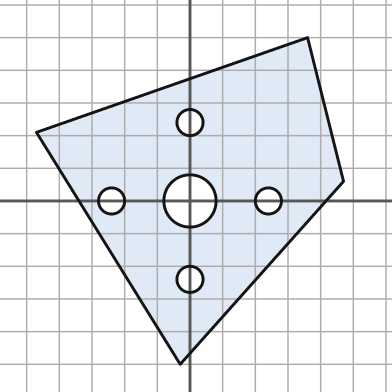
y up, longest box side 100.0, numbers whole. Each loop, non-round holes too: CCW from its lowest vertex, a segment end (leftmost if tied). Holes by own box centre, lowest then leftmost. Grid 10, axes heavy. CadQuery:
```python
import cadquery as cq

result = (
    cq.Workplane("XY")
    .moveTo(-3.0, -50.0)
    .lineTo(47.0, 6.0)
    .lineTo(36.0, 50.0)
    .lineTo(-47.0, 21.0)
    .close()
    .moveTo(0.0, -24.0)
    .circle(4.0)
    .moveTo(-24.0, 0.0)
    .circle(4.0)
    .moveTo(0.0, 0.0)
    .circle(8.0)
    .moveTo(24.0, 0.0)
    .circle(4.0)
    .moveTo(0.0, 24.0)
    .circle(4.0)
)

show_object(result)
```